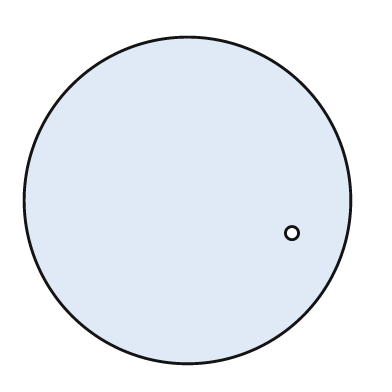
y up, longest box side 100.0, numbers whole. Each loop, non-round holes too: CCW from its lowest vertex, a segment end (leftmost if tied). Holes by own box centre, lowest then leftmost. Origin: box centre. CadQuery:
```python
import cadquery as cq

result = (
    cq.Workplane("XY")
    .moveTo(0.0, 0.0)
    .circle(50.0)
    .moveTo(32.0, -10.0)
    .circle(2.0)
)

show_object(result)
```